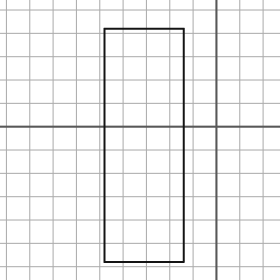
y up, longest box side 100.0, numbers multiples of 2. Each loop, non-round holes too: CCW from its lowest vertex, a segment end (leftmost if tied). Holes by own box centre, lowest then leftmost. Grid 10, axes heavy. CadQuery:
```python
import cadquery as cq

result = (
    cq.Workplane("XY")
    .moveTo(-48.0, -58.0)
    .lineTo(-14.0, -58.0)
    .lineTo(-14.0, 42.0)
    .lineTo(-48.0, 42.0)
    .close()
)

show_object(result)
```